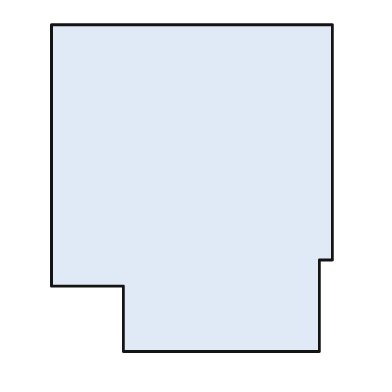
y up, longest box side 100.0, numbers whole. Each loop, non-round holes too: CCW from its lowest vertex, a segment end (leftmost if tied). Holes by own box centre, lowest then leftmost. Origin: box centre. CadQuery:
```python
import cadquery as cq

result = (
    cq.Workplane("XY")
    .moveTo(-21.0, -50.0)
    .lineTo(39.0, -50.0)
    .lineTo(39.0, -22.0)
    .lineTo(43.0, -22.0)
    .lineTo(43.0, 50.0)
    .lineTo(-43.0, 50.0)
    .lineTo(-43.0, -30.0)
    .lineTo(-21.0, -30.0)
    .close()
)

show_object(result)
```